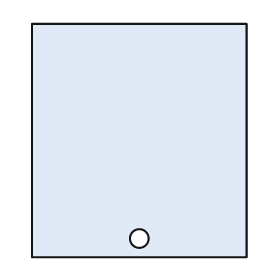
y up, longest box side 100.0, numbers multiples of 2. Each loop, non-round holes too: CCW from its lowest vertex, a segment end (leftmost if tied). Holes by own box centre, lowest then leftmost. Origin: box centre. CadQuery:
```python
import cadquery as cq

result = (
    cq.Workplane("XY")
    .moveTo(-46.0, -50.0)
    .lineTo(46.0, -50.0)
    .lineTo(46.0, 50.0)
    .lineTo(-46.0, 50.0)
    .close()
    .moveTo(0.0, -42.0)
    .circle(4.0)
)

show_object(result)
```